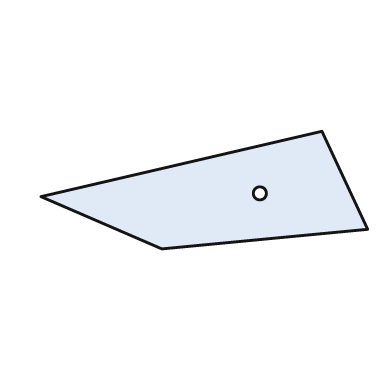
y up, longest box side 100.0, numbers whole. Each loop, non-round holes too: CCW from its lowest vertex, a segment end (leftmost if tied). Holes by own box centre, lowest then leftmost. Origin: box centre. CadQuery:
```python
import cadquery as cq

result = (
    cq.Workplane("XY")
    .moveTo(-13.0, -18.0)
    .lineTo(50.0, -12.0)
    .lineTo(36.0, 18.0)
    .lineTo(-50.0, -2.0)
    .close()
    .moveTo(17.0, -1.0)
    .circle(2.0)
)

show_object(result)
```